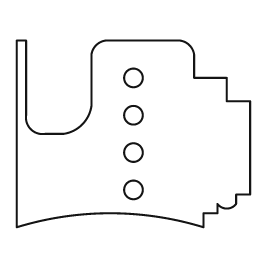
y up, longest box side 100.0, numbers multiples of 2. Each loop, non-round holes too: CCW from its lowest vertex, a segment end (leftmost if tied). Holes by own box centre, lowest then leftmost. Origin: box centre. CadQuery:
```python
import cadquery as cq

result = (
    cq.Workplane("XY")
    .moveTo(-50.0, -40.0)
    .threePointArc((-10.0, -34.0), (30.0, -40.0))
    .lineTo(30.0, -34.0)
    .lineTo(36.0, -34.0)
    .lineTo(36.0, -30.0)
    .threePointArc((40.0, -32.0), (44.0, -30.0))
    .lineTo(44.0, -26.0)
    .lineTo(50.0, -26.0)
    .lineTo(50.0, 14.0)
    .lineTo(40.0, 14.0)
    .lineTo(40.0, 24.0)
    .lineTo(26.0, 24.0)
    .lineTo(26.0, 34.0)
    .threePointArc((24.0, 38.0), (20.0, 40.0))
    .lineTo(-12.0, 40.0)
    .threePointArc((-16.0, 38.0), (-18.0, 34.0))
    .lineTo(-18.0, 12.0)
    .threePointArc((-22.0, 4.0), (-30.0, 0.0))
    .lineTo(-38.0, 0.0)
    .threePointArc((-44.0, 2.0), (-46.0, 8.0))
    .lineTo(-46.0, 40.0)
    .lineTo(-50.0, 40.0)
    .close()
    .moveTo(0.0, -24.0)
    .circle(4.0)
    .moveTo(0.0, -8.0)
    .circle(4.0)
    .moveTo(0.0, 8.0)
    .circle(4.0)
    .moveTo(0.0, 24.0)
    .circle(4.0)
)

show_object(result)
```